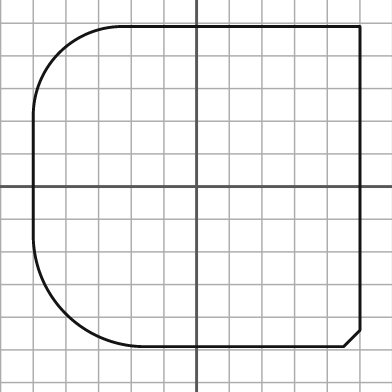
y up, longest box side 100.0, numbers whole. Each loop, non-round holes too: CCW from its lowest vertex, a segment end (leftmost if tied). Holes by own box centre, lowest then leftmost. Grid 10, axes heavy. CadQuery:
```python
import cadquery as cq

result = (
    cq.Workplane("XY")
    .moveTo(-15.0, -49.0)
    .lineTo(45.0, -49.0)
    .lineTo(50.0, -44.0)
    .lineTo(50.0, 49.0)
    .lineTo(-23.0, 49.0)
    .threePointArc((-42.0, 41.0), (-50.0, 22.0))
    .lineTo(-50.0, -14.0)
    .threePointArc((-40.0, -39.0), (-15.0, -49.0))
    .close()
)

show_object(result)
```